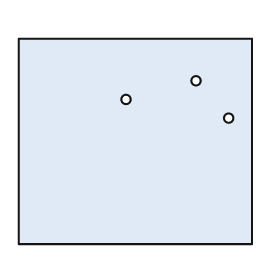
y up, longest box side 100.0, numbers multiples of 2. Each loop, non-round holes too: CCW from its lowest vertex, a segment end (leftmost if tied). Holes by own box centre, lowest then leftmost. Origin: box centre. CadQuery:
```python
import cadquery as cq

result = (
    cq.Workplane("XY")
    .moveTo(-50.0, -44.0)
    .lineTo(50.0, -44.0)
    .lineTo(50.0, 44.0)
    .lineTo(-50.0, 44.0)
    .close()
    .moveTo(40.0, 10.0)
    .circle(2.0)
    .moveTo(-4.0, 18.0)
    .circle(2.0)
    .moveTo(26.0, 26.0)
    .circle(2.0)
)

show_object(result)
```